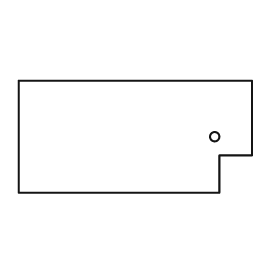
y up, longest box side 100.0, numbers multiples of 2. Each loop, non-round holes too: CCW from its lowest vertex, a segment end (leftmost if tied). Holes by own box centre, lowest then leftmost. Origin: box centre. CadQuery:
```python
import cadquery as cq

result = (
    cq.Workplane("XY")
    .moveTo(-50.0, -24.0)
    .lineTo(36.0, -24.0)
    .lineTo(36.0, -8.0)
    .lineTo(50.0, -8.0)
    .lineTo(50.0, 24.0)
    .lineTo(-50.0, 24.0)
    .close()
    .moveTo(34.0, 0.0)
    .circle(2.0)
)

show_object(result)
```